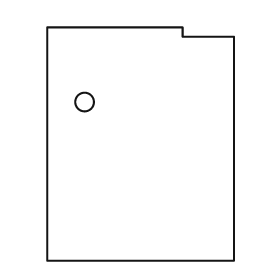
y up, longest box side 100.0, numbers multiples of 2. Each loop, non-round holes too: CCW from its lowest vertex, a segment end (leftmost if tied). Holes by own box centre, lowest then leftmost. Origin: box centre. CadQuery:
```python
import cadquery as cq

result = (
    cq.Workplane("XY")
    .moveTo(-40.0, -50.0)
    .lineTo(40.0, -50.0)
    .lineTo(40.0, 46.0)
    .lineTo(18.0, 46.0)
    .lineTo(18.0, 50.0)
    .lineTo(-40.0, 50.0)
    .close()
    .moveTo(-24.0, 18.0)
    .circle(4.0)
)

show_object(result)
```